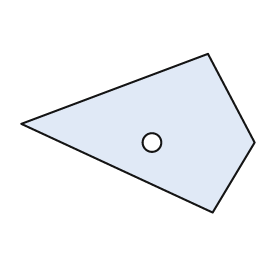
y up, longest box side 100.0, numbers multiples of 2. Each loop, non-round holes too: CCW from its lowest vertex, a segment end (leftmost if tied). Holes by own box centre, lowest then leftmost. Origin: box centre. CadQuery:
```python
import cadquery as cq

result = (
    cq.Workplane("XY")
    .moveTo(32.0, -34.0)
    .lineTo(50.0, -4.0)
    .lineTo(30.0, 34.0)
    .lineTo(-50.0, 4.0)
    .close()
    .moveTo(6.0, -4.0)
    .circle(4.0)
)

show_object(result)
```